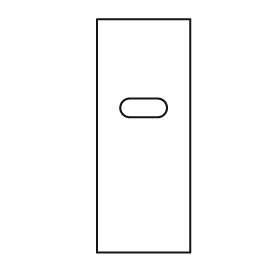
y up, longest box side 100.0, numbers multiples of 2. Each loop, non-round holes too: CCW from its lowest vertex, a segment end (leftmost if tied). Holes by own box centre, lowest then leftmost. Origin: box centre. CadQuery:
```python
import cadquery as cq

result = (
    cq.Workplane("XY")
    .moveTo(-20.0, -50.0)
    .lineTo(20.0, -50.0)
    .lineTo(20.0, 50.0)
    .lineTo(-20.0, 50.0)
    .close()
    .moveTo(-6.0, 8.0)
    .lineTo(6.0, 8.0)
    .threePointArc((10.0, 12.0), (6.0, 16.0))
    .lineTo(-6.0, 16.0)
    .threePointArc((-10.0, 12.0), (-6.0, 8.0))
    .close()
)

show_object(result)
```